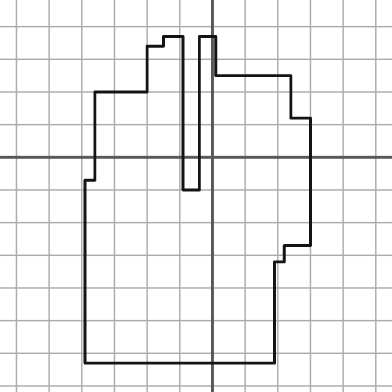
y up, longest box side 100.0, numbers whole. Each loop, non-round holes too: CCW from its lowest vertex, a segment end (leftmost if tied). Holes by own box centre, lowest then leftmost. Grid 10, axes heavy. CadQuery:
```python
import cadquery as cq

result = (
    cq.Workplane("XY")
    .moveTo(-39.0, -63.0)
    .lineTo(19.0, -63.0)
    .lineTo(19.0, -32.0)
    .lineTo(22.0, -32.0)
    .lineTo(22.0, -27.0)
    .lineTo(30.0, -27.0)
    .lineTo(30.0, 12.0)
    .lineTo(24.0, 12.0)
    .lineTo(24.0, 25.0)
    .lineTo(1.0, 25.0)
    .lineTo(1.0, 37.0)
    .lineTo(-4.0, 37.0)
    .lineTo(-4.0, -10.0)
    .lineTo(-9.0, -10.0)
    .lineTo(-9.0, 37.0)
    .lineTo(-15.0, 37.0)
    .lineTo(-15.0, 34.0)
    .lineTo(-20.0, 34.0)
    .lineTo(-20.0, 20.0)
    .lineTo(-36.0, 20.0)
    .lineTo(-36.0, -7.0)
    .lineTo(-39.0, -7.0)
    .close()
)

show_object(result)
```